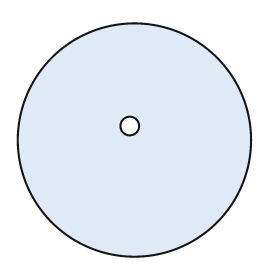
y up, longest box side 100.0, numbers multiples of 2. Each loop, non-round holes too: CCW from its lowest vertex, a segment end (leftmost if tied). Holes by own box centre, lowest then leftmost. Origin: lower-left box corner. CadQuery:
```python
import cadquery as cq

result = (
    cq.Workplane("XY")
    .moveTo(50.0, 50.0)
    .circle(50.0)
    .moveTo(48.0, 56.0)
    .circle(4.0)
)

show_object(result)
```